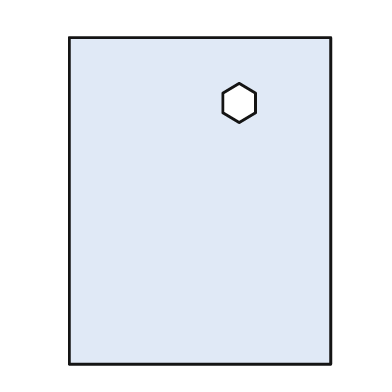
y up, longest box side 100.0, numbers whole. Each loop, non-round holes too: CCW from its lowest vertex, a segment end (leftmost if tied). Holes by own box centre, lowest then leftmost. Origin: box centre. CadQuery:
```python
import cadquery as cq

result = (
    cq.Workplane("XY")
    .moveTo(-40.0, -50.0)
    .lineTo(40.0, -50.0)
    .lineTo(40.0, 50.0)
    .lineTo(-40.0, 50.0)
    .close()
    .moveTo(12.0, 24.0)
    .lineTo(17.0, 27.0)
    .lineTo(17.0, 33.0)
    .lineTo(12.0, 36.0)
    .lineTo(7.0, 33.0)
    .lineTo(7.0, 27.0)
    .close()
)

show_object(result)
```